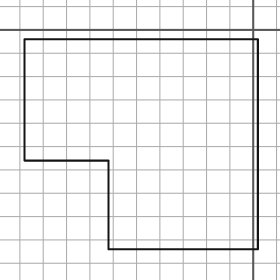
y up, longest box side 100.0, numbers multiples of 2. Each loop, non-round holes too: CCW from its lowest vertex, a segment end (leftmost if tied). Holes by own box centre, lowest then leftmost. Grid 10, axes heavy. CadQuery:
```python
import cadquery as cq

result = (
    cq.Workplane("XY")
    .moveTo(-62.0, -94.0)
    .lineTo(2.0, -94.0)
    .lineTo(2.0, -4.0)
    .lineTo(-98.0, -4.0)
    .lineTo(-98.0, -56.0)
    .lineTo(-62.0, -56.0)
    .close()
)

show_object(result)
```